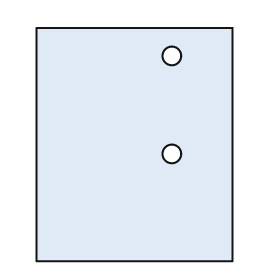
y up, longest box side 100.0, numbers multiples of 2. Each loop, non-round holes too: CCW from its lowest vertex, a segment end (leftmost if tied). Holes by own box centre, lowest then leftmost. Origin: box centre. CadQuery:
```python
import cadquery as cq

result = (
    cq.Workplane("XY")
    .moveTo(-42.0, -50.0)
    .lineTo(42.0, -50.0)
    .lineTo(42.0, 50.0)
    .lineTo(-42.0, 50.0)
    .close()
    .moveTo(16.0, -4.0)
    .circle(4.0)
    .moveTo(16.0, 38.0)
    .circle(4.0)
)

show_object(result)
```